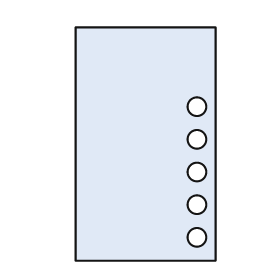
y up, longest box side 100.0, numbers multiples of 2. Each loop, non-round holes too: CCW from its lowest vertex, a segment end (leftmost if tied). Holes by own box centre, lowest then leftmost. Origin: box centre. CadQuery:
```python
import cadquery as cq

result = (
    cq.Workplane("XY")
    .moveTo(-30.0, -50.0)
    .lineTo(30.0, -50.0)
    .lineTo(30.0, 50.0)
    .lineTo(-30.0, 50.0)
    .close()
    .moveTo(22.0, -40.0)
    .circle(4.0)
    .moveTo(22.0, -26.0)
    .circle(4.0)
    .moveTo(22.0, -12.0)
    .circle(4.0)
    .moveTo(22.0, 2.0)
    .circle(4.0)
    .moveTo(22.0, 16.0)
    .circle(4.0)
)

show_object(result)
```